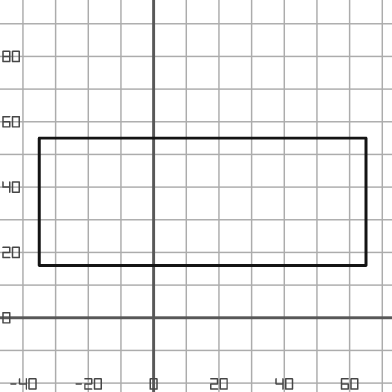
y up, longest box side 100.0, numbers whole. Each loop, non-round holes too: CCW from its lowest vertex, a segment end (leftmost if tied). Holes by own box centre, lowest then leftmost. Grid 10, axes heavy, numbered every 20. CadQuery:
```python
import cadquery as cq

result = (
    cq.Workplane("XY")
    .moveTo(-35.0, 16.0)
    .lineTo(65.0, 16.0)
    .lineTo(65.0, 55.0)
    .lineTo(-35.0, 55.0)
    .close()
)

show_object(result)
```